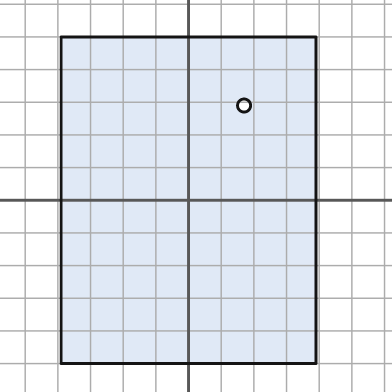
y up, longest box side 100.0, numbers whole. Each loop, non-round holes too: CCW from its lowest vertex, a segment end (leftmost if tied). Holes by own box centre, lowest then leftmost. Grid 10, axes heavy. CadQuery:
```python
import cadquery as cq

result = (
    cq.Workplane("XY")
    .moveTo(-39.0, -50.0)
    .lineTo(39.0, -50.0)
    .lineTo(39.0, 50.0)
    .lineTo(-39.0, 50.0)
    .close()
    .moveTo(17.0, 29.0)
    .circle(2.0)
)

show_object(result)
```